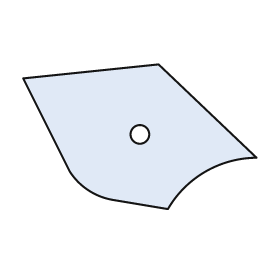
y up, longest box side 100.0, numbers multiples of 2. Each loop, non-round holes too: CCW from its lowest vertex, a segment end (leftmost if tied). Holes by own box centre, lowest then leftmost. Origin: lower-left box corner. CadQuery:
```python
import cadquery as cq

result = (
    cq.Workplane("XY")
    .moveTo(62.0, 0.0)
    .threePointArc((78.0, 16.0), (100.0, 22.0))
    .lineTo(58.0, 62.0)
    .lineTo(0.0, 56.0)
    .lineTo(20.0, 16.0)
    .threePointArc((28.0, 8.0), (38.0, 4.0))
    .close()
    .moveTo(50.0, 32.0)
    .circle(4.0)
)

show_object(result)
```